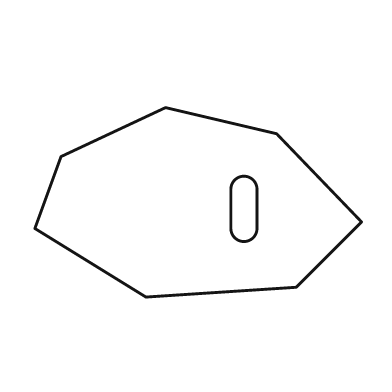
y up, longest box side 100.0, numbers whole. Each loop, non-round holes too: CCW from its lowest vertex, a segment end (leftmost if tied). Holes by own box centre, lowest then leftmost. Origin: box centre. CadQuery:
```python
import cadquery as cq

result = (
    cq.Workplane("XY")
    .moveTo(-16.0, -29.0)
    .lineTo(30.0, -26.0)
    .lineTo(50.0, -6.0)
    .lineTo(24.0, 21.0)
    .lineTo(-10.0, 29.0)
    .lineTo(-42.0, 14.0)
    .lineTo(-50.0, -8.0)
    .close()
    .moveTo(10.0, -8.0)
    .threePointArc((14.0, -12.0), (18.0, -8.0))
    .lineTo(18.0, 4.0)
    .threePointArc((14.0, 8.0), (10.0, 4.0))
    .close()
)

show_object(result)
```